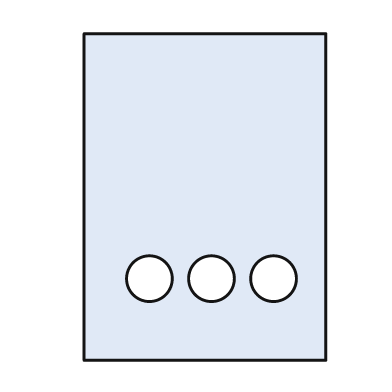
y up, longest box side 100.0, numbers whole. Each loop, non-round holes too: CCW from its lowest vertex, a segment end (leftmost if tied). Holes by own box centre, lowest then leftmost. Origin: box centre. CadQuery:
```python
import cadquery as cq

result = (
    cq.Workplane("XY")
    .moveTo(-37.0, -50.0)
    .lineTo(37.0, -50.0)
    .lineTo(37.0, 50.0)
    .lineTo(-37.0, 50.0)
    .close()
    .moveTo(-17.0, -25.0)
    .circle(7.0)
    .moveTo(2.0, -25.0)
    .circle(7.0)
    .moveTo(21.0, -25.0)
    .circle(7.0)
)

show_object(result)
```